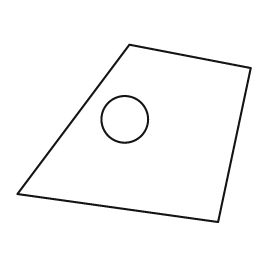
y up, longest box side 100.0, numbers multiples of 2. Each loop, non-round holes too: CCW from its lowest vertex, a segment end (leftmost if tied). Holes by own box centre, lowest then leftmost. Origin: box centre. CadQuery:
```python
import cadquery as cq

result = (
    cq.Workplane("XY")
    .moveTo(36.0, -38.0)
    .lineTo(50.0, 28.0)
    .lineTo(-2.0, 38.0)
    .lineTo(-50.0, -26.0)
    .close()
    .moveTo(-4.0, 6.0)
    .circle(10.0)
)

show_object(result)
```